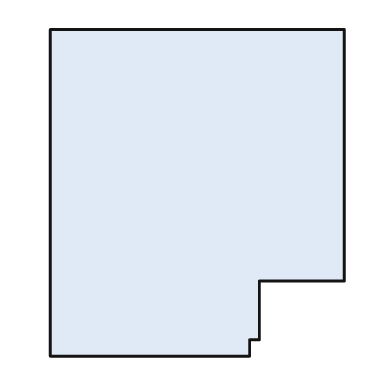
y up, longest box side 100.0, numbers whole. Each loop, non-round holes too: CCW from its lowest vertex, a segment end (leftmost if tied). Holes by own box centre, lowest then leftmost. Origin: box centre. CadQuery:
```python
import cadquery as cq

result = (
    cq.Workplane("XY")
    .moveTo(-45.0, -50.0)
    .lineTo(16.0, -50.0)
    .lineTo(16.0, -45.0)
    .lineTo(19.0, -45.0)
    .lineTo(19.0, -27.0)
    .lineTo(45.0, -27.0)
    .lineTo(45.0, 50.0)
    .lineTo(-45.0, 50.0)
    .close()
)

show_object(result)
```